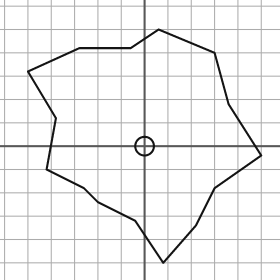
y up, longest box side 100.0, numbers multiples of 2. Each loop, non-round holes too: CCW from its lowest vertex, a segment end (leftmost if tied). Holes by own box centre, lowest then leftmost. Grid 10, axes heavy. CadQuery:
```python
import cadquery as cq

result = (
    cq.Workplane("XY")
    .moveTo(8.0, -50.0)
    .lineTo(22.0, -34.0)
    .lineTo(30.0, -18.0)
    .lineTo(50.0, -4.0)
    .lineTo(36.0, 18.0)
    .lineTo(30.0, 40.0)
    .lineTo(6.0, 50.0)
    .lineTo(-6.0, 42.0)
    .lineTo(-28.0, 42.0)
    .lineTo(-50.0, 32.0)
    .lineTo(-38.0, 12.0)
    .lineTo(-42.0, -10.0)
    .lineTo(-26.0, -18.0)
    .lineTo(-20.0, -24.0)
    .lineTo(-4.0, -32.0)
    .close()
    .moveTo(0.0, 0.0)
    .circle(4.0)
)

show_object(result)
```